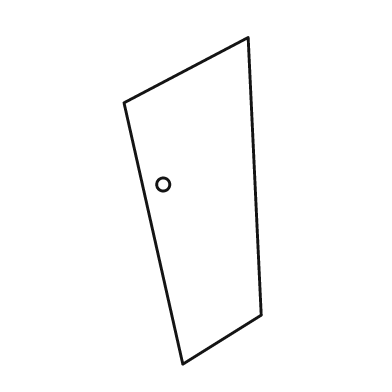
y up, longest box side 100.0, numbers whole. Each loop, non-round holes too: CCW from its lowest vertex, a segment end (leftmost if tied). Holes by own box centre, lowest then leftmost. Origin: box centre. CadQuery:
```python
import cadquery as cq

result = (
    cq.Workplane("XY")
    .moveTo(-3.0, -50.0)
    .lineTo(21.0, -35.0)
    .lineTo(17.0, 50.0)
    .lineTo(-21.0, 30.0)
    .close()
    .moveTo(-9.0, 5.0)
    .circle(2.0)
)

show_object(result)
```